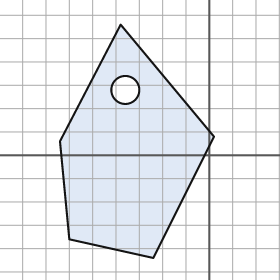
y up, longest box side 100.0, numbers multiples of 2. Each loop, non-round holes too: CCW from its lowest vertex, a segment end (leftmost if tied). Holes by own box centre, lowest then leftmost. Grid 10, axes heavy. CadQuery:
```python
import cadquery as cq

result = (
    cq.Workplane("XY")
    .moveTo(-24.0, -44.0)
    .lineTo(2.0, 8.0)
    .lineTo(-38.0, 56.0)
    .lineTo(-64.0, 6.0)
    .lineTo(-60.0, -36.0)
    .close()
    .moveTo(-36.0, 28.0)
    .circle(6.0)
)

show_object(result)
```